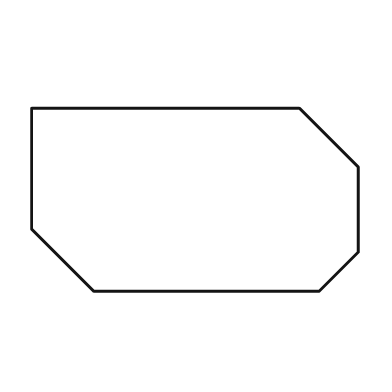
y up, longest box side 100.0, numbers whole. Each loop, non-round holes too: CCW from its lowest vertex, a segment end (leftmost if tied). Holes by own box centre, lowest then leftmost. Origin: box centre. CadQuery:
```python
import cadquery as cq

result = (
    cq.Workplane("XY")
    .moveTo(-31.0, -28.0)
    .lineTo(38.0, -28.0)
    .lineTo(50.0, -16.0)
    .lineTo(50.0, 10.0)
    .lineTo(32.0, 28.0)
    .lineTo(-50.0, 28.0)
    .lineTo(-50.0, -9.0)
    .close()
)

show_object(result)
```